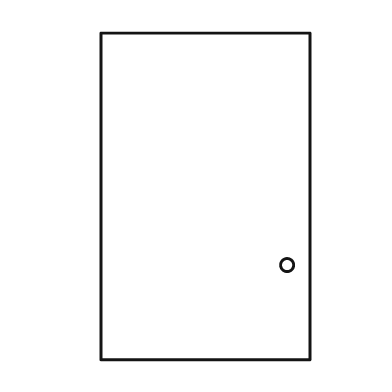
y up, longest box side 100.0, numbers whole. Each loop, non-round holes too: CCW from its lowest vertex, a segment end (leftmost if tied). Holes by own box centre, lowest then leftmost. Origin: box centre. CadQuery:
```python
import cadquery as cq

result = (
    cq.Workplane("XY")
    .moveTo(-32.0, -50.0)
    .lineTo(32.0, -50.0)
    .lineTo(32.0, 50.0)
    .lineTo(-32.0, 50.0)
    .close()
    .moveTo(25.0, -21.0)
    .circle(2.0)
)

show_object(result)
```